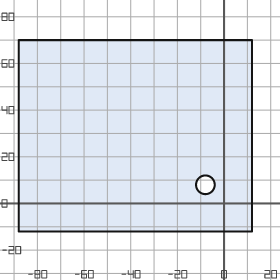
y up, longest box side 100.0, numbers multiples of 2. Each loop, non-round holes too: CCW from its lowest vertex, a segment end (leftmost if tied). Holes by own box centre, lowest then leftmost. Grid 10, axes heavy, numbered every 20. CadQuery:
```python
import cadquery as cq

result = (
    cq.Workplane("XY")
    .moveTo(-88.0, -12.0)
    .lineTo(12.0, -12.0)
    .lineTo(12.0, 70.0)
    .lineTo(-88.0, 70.0)
    .close()
    .moveTo(-8.0, 8.0)
    .circle(4.0)
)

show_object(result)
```